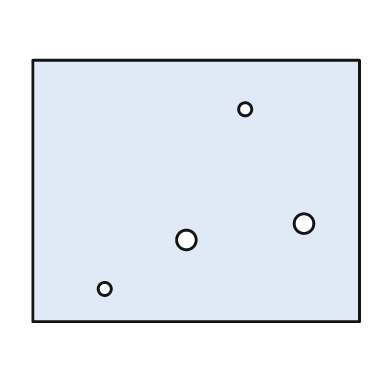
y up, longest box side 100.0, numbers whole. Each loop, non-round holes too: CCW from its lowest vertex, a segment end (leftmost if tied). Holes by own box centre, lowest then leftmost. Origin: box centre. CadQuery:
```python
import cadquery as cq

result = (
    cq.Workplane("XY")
    .moveTo(-50.0, -40.0)
    .lineTo(50.0, -40.0)
    .lineTo(50.0, 40.0)
    .lineTo(-50.0, 40.0)
    .close()
    .moveTo(-28.0, -30.0)
    .circle(2.0)
    .moveTo(-3.0, -15.0)
    .circle(3.0)
    .moveTo(33.0, -10.0)
    .circle(3.0)
    .moveTo(15.0, 25.0)
    .circle(2.0)
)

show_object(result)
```